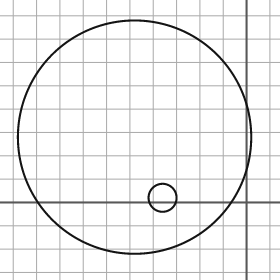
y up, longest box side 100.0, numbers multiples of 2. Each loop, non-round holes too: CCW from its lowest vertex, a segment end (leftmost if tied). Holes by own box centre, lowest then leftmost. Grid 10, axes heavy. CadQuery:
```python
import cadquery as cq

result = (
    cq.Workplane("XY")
    .moveTo(-48.0, 28.0)
    .circle(50.0)
    .moveTo(-36.0, 2.0)
    .circle(6.0)
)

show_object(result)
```